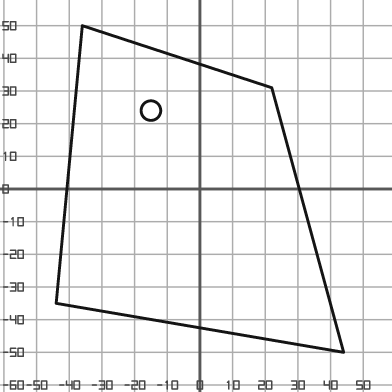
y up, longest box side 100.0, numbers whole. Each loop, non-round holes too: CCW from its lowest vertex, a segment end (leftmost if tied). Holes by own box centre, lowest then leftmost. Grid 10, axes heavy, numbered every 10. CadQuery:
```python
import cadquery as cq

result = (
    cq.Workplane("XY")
    .moveTo(44.0, -50.0)
    .lineTo(22.0, 31.0)
    .lineTo(-36.0, 50.0)
    .lineTo(-44.0, -35.0)
    .close()
    .moveTo(-15.0, 24.0)
    .circle(3.0)
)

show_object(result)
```